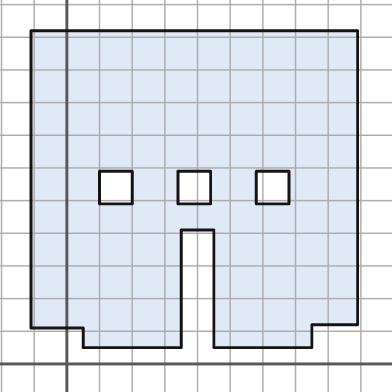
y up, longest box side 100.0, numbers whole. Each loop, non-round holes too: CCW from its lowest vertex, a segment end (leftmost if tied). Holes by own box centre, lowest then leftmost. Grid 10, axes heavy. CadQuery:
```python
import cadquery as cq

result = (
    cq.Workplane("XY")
    .moveTo(5.0, 5.0)
    .lineTo(35.0, 5.0)
    .lineTo(35.0, 41.0)
    .lineTo(45.0, 41.0)
    .lineTo(45.0, 5.0)
    .lineTo(75.0, 5.0)
    .lineTo(75.0, 12.0)
    .lineTo(89.0, 12.0)
    .lineTo(89.0, 102.0)
    .lineTo(-11.0, 102.0)
    .lineTo(-11.0, 11.0)
    .lineTo(5.0, 11.0)
    .close()
    .moveTo(10.0, 49.0)
    .lineTo(20.0, 49.0)
    .lineTo(20.0, 59.0)
    .lineTo(10.0, 59.0)
    .close()
    .moveTo(34.0, 49.0)
    .lineTo(44.0, 49.0)
    .lineTo(44.0, 59.0)
    .lineTo(34.0, 59.0)
    .close()
    .moveTo(58.0, 49.0)
    .lineTo(68.0, 49.0)
    .lineTo(68.0, 59.0)
    .lineTo(58.0, 59.0)
    .close()
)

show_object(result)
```